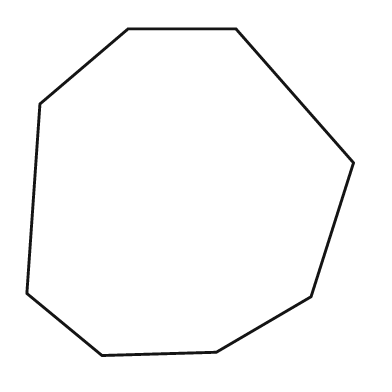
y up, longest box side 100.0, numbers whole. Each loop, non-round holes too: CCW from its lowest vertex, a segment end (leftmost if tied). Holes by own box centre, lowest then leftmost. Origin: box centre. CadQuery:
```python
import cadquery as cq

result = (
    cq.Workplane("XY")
    .moveTo(-27.0, -50.0)
    .lineTo(8.0, -49.0)
    .lineTo(37.0, -32.0)
    .lineTo(50.0, 9.0)
    .lineTo(14.0, 50.0)
    .lineTo(-19.0, 50.0)
    .lineTo(-46.0, 27.0)
    .lineTo(-50.0, -31.0)
    .close()
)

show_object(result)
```